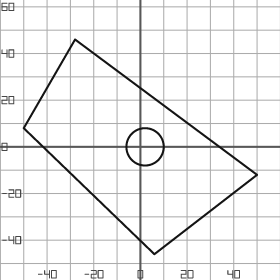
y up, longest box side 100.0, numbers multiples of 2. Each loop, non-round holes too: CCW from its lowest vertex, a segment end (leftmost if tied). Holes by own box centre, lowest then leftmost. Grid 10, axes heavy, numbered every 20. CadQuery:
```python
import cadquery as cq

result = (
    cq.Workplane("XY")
    .moveTo(6.0, -46.0)
    .lineTo(50.0, -12.0)
    .lineTo(-28.0, 46.0)
    .lineTo(-50.0, 8.0)
    .close()
    .moveTo(2.0, 0.0)
    .circle(8.0)
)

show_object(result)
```